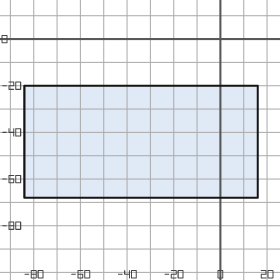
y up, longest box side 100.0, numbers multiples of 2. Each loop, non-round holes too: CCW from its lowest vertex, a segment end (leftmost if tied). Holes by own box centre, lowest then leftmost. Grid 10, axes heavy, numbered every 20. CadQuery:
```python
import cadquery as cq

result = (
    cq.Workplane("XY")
    .moveTo(-84.0, -68.0)
    .lineTo(16.0, -68.0)
    .lineTo(16.0, -20.0)
    .lineTo(-84.0, -20.0)
    .close()
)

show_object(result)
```